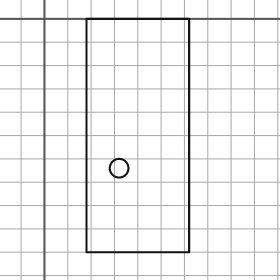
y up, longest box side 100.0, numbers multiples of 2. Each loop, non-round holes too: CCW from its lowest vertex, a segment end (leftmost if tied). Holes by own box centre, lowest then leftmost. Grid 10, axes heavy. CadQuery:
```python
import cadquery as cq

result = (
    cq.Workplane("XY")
    .moveTo(18.0, -100.0)
    .lineTo(62.0, -100.0)
    .lineTo(62.0, 0.0)
    .lineTo(18.0, 0.0)
    .close()
    .moveTo(32.0, -64.0)
    .circle(4.0)
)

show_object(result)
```